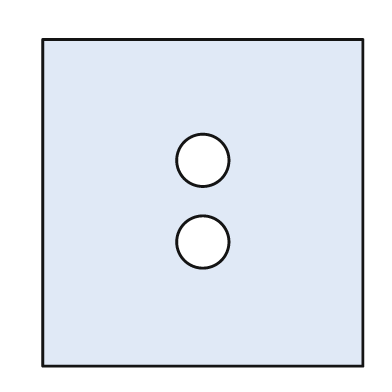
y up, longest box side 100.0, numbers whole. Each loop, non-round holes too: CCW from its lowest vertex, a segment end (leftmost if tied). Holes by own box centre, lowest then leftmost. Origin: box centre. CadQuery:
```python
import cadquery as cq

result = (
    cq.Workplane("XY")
    .moveTo(-49.0, -50.0)
    .lineTo(49.0, -50.0)
    .lineTo(49.0, 50.0)
    .lineTo(-49.0, 50.0)
    .close()
    .moveTo(0.0, -12.0)
    .circle(8.0)
    .moveTo(0.0, 13.0)
    .circle(8.0)
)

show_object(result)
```